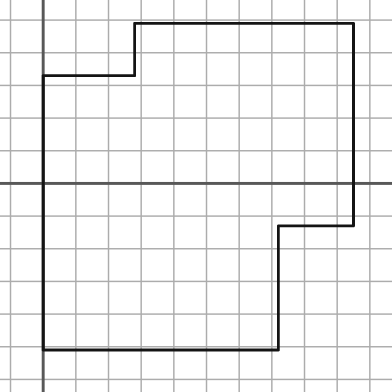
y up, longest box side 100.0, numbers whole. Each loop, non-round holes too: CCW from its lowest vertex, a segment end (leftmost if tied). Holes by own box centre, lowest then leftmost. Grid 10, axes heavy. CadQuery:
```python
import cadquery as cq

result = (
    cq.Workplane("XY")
    .moveTo(0.0, -51.0)
    .lineTo(72.0, -51.0)
    .lineTo(72.0, -13.0)
    .lineTo(95.0, -13.0)
    .lineTo(95.0, 49.0)
    .lineTo(28.0, 49.0)
    .lineTo(28.0, 33.0)
    .lineTo(0.0, 33.0)
    .close()
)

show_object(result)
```